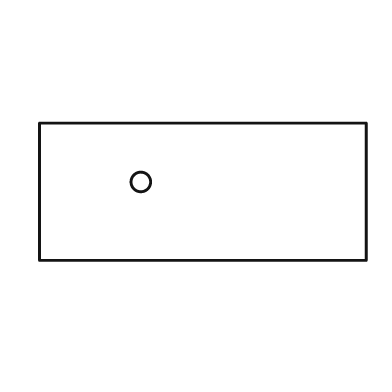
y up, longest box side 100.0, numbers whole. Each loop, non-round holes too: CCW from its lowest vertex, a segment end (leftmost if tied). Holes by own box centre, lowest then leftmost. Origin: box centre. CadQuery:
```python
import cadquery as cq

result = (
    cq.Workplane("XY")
    .moveTo(-50.0, -21.0)
    .lineTo(50.0, -21.0)
    .lineTo(50.0, 21.0)
    .lineTo(-50.0, 21.0)
    .close()
    .moveTo(-19.0, 3.0)
    .circle(3.0)
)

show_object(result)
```